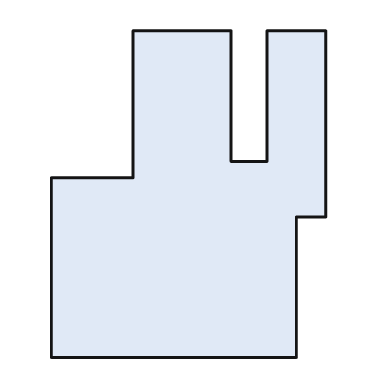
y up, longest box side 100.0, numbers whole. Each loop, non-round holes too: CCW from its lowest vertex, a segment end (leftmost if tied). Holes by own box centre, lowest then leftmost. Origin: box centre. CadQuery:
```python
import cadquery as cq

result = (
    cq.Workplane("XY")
    .moveTo(-42.0, -50.0)
    .lineTo(33.0, -50.0)
    .lineTo(33.0, -7.0)
    .lineTo(42.0, -7.0)
    .lineTo(42.0, 50.0)
    .lineTo(24.0, 50.0)
    .lineTo(24.0, 10.0)
    .lineTo(13.0, 10.0)
    .lineTo(13.0, 50.0)
    .lineTo(-17.0, 50.0)
    .lineTo(-17.0, 5.0)
    .lineTo(-42.0, 5.0)
    .close()
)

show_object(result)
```